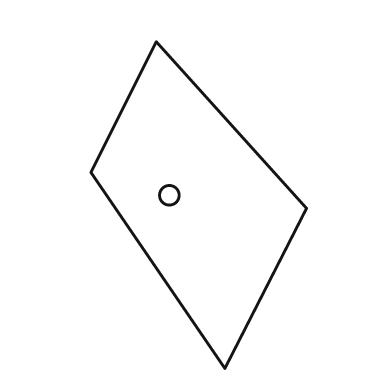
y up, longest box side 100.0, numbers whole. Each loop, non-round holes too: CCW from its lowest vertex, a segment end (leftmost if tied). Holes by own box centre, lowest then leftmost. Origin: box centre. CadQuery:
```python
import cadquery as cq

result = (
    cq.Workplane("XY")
    .moveTo(8.0, -50.0)
    .lineTo(33.0, -1.0)
    .lineTo(-13.0, 50.0)
    .lineTo(-33.0, 10.0)
    .close()
    .moveTo(-9.0, 3.0)
    .circle(3.0)
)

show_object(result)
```